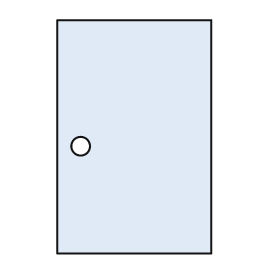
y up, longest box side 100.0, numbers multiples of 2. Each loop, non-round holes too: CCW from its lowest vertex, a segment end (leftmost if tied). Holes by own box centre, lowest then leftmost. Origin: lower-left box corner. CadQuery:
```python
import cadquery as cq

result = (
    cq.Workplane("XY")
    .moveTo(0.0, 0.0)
    .lineTo(66.0, 0.0)
    .lineTo(66.0, 100.0)
    .lineTo(0.0, 100.0)
    .close()
    .moveTo(10.0, 46.0)
    .circle(4.0)
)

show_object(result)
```